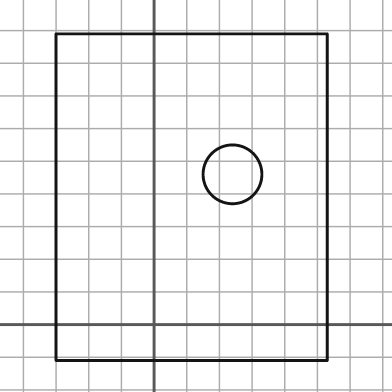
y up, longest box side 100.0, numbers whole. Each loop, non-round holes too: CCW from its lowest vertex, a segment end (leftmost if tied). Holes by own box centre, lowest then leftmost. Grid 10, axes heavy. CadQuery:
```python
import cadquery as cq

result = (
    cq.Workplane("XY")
    .moveTo(-30.0, -11.0)
    .lineTo(53.0, -11.0)
    .lineTo(53.0, 89.0)
    .lineTo(-30.0, 89.0)
    .close()
    .moveTo(24.0, 46.0)
    .circle(9.0)
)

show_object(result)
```